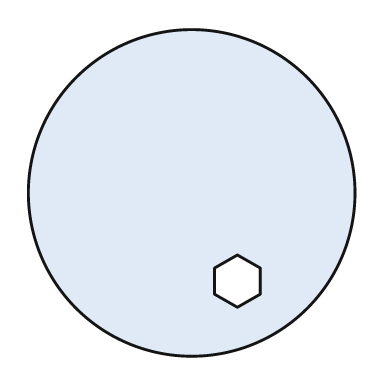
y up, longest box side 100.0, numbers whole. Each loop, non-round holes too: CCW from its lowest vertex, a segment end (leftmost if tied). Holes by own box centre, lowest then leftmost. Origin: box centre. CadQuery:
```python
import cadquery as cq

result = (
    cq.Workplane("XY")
    .moveTo(0.0, 0.0)
    .circle(50.0)
    .moveTo(14.0, -35.0)
    .lineTo(21.0, -31.0)
    .lineTo(21.0, -23.0)
    .lineTo(14.0, -19.0)
    .lineTo(7.0, -23.0)
    .lineTo(7.0, -31.0)
    .close()
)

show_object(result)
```